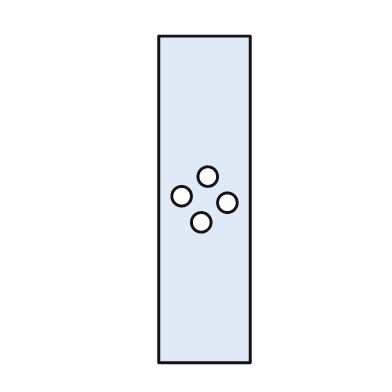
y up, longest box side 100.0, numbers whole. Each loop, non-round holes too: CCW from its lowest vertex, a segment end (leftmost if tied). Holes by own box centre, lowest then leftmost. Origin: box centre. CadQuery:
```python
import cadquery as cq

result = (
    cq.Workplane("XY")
    .moveTo(-14.0, -50.0)
    .lineTo(14.0, -50.0)
    .lineTo(14.0, 50.0)
    .lineTo(-14.0, 50.0)
    .close()
    .moveTo(-1.0, -7.0)
    .circle(3.0)
    .moveTo(7.0, -1.0)
    .circle(3.0)
    .moveTo(-7.0, 1.0)
    .circle(3.0)
    .moveTo(1.0, 7.0)
    .circle(3.0)
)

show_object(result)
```